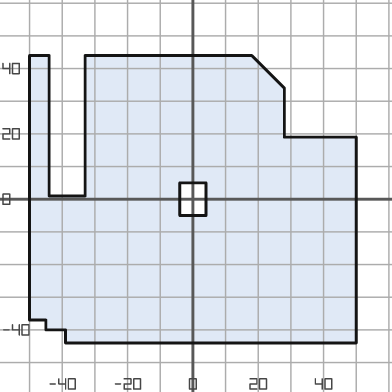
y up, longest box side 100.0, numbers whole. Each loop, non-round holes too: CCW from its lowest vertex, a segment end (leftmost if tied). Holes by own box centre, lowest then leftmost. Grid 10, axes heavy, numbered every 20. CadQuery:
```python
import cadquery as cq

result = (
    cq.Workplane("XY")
    .moveTo(-39.0, -44.0)
    .lineTo(50.0, -44.0)
    .lineTo(50.0, 19.0)
    .lineTo(28.0, 19.0)
    .lineTo(28.0, 34.0)
    .lineTo(18.0, 44.0)
    .lineTo(-33.0, 44.0)
    .lineTo(-33.0, 1.0)
    .lineTo(-44.0, 1.0)
    .lineTo(-44.0, 44.0)
    .lineTo(-50.0, 44.0)
    .lineTo(-50.0, -37.0)
    .lineTo(-45.0, -37.0)
    .lineTo(-45.0, -40.0)
    .lineTo(-39.0, -40.0)
    .close()
    .moveTo(-4.0, -5.0)
    .lineTo(4.0, -5.0)
    .lineTo(4.0, 5.0)
    .lineTo(-4.0, 5.0)
    .close()
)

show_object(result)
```